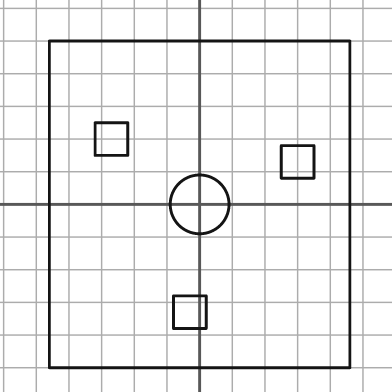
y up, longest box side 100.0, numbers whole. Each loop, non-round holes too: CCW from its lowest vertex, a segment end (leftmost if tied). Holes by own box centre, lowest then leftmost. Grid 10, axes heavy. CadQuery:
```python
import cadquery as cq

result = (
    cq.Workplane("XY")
    .moveTo(-46.0, -50.0)
    .lineTo(46.0, -50.0)
    .lineTo(46.0, 50.0)
    .lineTo(-46.0, 50.0)
    .close()
    .moveTo(-8.0, -38.0)
    .lineTo(2.0, -38.0)
    .lineTo(2.0, -28.0)
    .lineTo(-8.0, -28.0)
    .close()
    .moveTo(0.0, 0.0)
    .circle(9.0)
    .moveTo(25.0, 8.0)
    .lineTo(35.0, 8.0)
    .lineTo(35.0, 18.0)
    .lineTo(25.0, 18.0)
    .close()
    .moveTo(-32.0, 15.0)
    .lineTo(-22.0, 15.0)
    .lineTo(-22.0, 25.0)
    .lineTo(-32.0, 25.0)
    .close()
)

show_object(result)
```